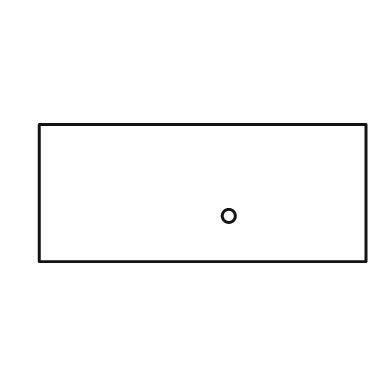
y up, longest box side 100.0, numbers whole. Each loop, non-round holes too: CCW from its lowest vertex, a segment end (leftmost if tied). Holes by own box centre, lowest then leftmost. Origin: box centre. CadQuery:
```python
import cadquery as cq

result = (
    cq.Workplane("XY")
    .moveTo(-50.0, -21.0)
    .lineTo(50.0, -21.0)
    .lineTo(50.0, 21.0)
    .lineTo(-50.0, 21.0)
    .close()
    .moveTo(8.0, -7.0)
    .circle(2.0)
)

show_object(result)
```